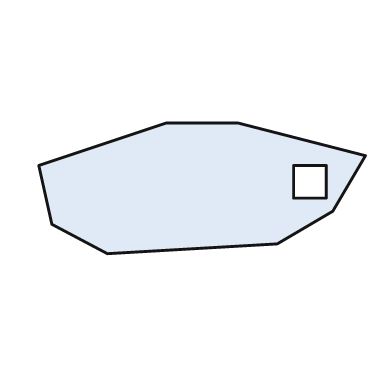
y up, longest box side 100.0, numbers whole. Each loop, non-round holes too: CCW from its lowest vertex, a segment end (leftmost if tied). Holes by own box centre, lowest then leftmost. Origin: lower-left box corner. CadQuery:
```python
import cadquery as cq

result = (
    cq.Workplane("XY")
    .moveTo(21.0, 0.0)
    .lineTo(73.0, 3.0)
    .lineTo(90.0, 13.0)
    .lineTo(100.0, 30.0)
    .lineTo(61.0, 40.0)
    .lineTo(39.0, 40.0)
    .lineTo(0.0, 27.0)
    .lineTo(4.0, 9.0)
    .close()
    .moveTo(78.0, 17.0)
    .lineTo(88.0, 17.0)
    .lineTo(88.0, 27.0)
    .lineTo(78.0, 27.0)
    .close()
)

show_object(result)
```